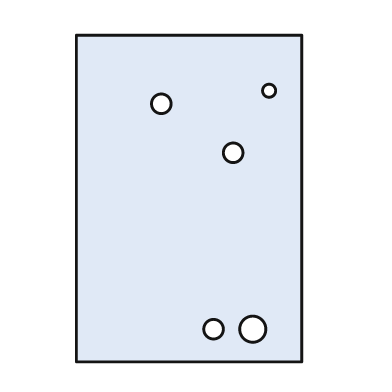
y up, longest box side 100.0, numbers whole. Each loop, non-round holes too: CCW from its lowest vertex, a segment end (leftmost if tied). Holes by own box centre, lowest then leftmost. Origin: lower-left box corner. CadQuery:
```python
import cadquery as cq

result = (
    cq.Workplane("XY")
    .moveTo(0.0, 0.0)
    .lineTo(69.0, 0.0)
    .lineTo(69.0, 100.0)
    .lineTo(0.0, 100.0)
    .close()
    .moveTo(42.0, 10.0)
    .circle(3.0)
    .moveTo(54.0, 10.0)
    .circle(4.0)
    .moveTo(48.0, 64.0)
    .circle(3.0)
    .moveTo(26.0, 79.0)
    .circle(3.0)
    .moveTo(59.0, 83.0)
    .circle(2.0)
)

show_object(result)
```